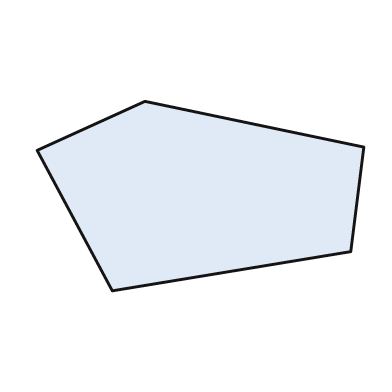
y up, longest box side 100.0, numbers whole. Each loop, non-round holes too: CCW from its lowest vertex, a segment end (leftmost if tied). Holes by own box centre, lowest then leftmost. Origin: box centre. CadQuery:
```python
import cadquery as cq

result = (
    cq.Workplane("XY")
    .moveTo(-27.0, -29.0)
    .lineTo(46.0, -17.0)
    .lineTo(50.0, 15.0)
    .lineTo(-17.0, 29.0)
    .lineTo(-50.0, 14.0)
    .close()
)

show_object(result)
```